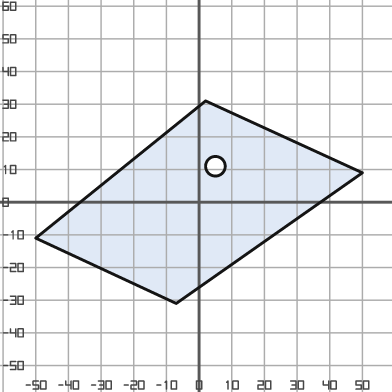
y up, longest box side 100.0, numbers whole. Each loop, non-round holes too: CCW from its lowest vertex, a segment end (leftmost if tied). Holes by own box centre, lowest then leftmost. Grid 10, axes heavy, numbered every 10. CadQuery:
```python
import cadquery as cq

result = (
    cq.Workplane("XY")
    .moveTo(-7.0, -31.0)
    .lineTo(50.0, 9.0)
    .lineTo(2.0, 31.0)
    .lineTo(-50.0, -11.0)
    .close()
    .moveTo(5.0, 11.0)
    .circle(3.0)
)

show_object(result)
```